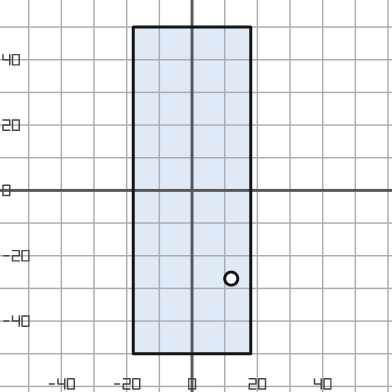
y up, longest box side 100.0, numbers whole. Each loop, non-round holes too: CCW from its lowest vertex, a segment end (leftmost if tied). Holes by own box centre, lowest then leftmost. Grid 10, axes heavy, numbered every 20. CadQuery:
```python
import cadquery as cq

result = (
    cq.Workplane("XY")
    .moveTo(-18.0, -50.0)
    .lineTo(18.0, -50.0)
    .lineTo(18.0, 50.0)
    .lineTo(-18.0, 50.0)
    .close()
    .moveTo(12.0, -27.0)
    .circle(2.0)
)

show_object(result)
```